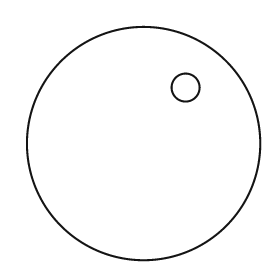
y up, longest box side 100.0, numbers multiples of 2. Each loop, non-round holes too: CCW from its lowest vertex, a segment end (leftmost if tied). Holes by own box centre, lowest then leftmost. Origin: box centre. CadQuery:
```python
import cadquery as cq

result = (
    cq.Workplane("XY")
    .moveTo(0.0, 0.0)
    .circle(50.0)
    .moveTo(18.0, 24.0)
    .circle(6.0)
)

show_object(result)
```